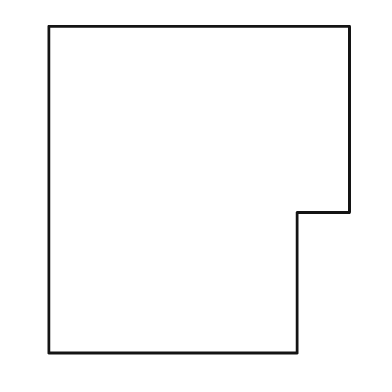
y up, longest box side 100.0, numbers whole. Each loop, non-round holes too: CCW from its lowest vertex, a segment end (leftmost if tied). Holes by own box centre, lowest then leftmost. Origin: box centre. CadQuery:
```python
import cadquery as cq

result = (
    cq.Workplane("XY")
    .moveTo(-46.0, -50.0)
    .lineTo(30.0, -50.0)
    .lineTo(30.0, -7.0)
    .lineTo(46.0, -7.0)
    .lineTo(46.0, 50.0)
    .lineTo(-46.0, 50.0)
    .close()
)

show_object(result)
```